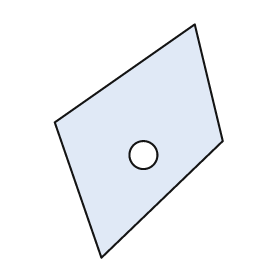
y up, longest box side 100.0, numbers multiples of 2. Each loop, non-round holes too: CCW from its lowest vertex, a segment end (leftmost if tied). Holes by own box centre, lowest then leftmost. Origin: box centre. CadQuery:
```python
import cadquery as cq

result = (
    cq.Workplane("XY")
    .moveTo(-16.0, -50.0)
    .lineTo(36.0, 0.0)
    .lineTo(24.0, 50.0)
    .lineTo(-36.0, 8.0)
    .close()
    .moveTo(2.0, -6.0)
    .circle(6.0)
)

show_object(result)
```